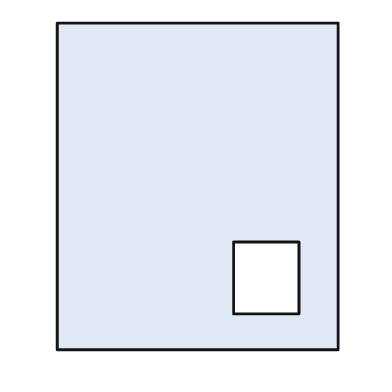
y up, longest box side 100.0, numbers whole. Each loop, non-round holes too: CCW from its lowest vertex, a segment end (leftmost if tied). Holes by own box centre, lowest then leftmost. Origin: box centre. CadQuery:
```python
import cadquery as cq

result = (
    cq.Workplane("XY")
    .moveTo(-43.0, -50.0)
    .lineTo(43.0, -50.0)
    .lineTo(43.0, 50.0)
    .lineTo(-43.0, 50.0)
    .close()
    .moveTo(11.0, -39.0)
    .lineTo(31.0, -39.0)
    .lineTo(31.0, -17.0)
    .lineTo(11.0, -17.0)
    .close()
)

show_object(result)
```